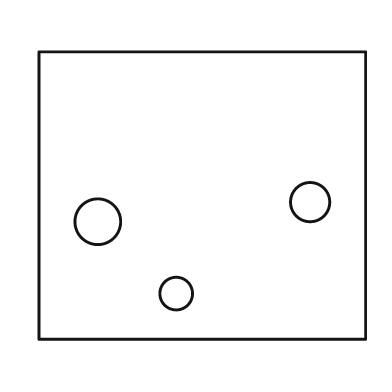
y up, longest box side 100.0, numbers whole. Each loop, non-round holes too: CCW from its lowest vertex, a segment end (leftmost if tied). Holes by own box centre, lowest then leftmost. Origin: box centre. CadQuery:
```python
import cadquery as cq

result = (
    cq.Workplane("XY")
    .moveTo(-50.0, -44.0)
    .lineTo(50.0, -44.0)
    .lineTo(50.0, 44.0)
    .lineTo(-50.0, 44.0)
    .close()
    .moveTo(-8.0, -30.0)
    .circle(5.0)
    .moveTo(-32.0, -8.0)
    .circle(7.0)
    .moveTo(33.0, -2.0)
    .circle(6.0)
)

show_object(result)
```